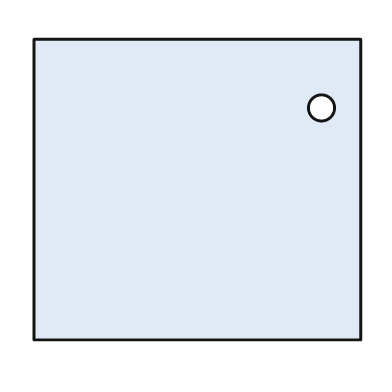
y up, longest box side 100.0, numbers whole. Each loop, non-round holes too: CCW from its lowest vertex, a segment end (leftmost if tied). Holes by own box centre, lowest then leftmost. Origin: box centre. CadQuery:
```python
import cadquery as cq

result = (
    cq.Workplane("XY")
    .moveTo(-50.0, -46.0)
    .lineTo(50.0, -46.0)
    .lineTo(50.0, 46.0)
    .lineTo(-50.0, 46.0)
    .close()
    .moveTo(38.0, 25.0)
    .circle(4.0)
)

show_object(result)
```